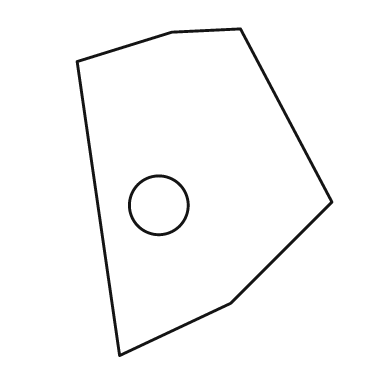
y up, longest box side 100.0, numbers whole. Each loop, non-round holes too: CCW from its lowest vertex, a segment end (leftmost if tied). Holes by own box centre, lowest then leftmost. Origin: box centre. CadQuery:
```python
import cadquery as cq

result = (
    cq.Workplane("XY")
    .moveTo(-26.0, -50.0)
    .lineTo(8.0, -34.0)
    .lineTo(39.0, -3.0)
    .lineTo(11.0, 50.0)
    .lineTo(-10.0, 49.0)
    .lineTo(-39.0, 40.0)
    .close()
    .moveTo(-14.0, -4.0)
    .circle(9.0)
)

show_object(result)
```